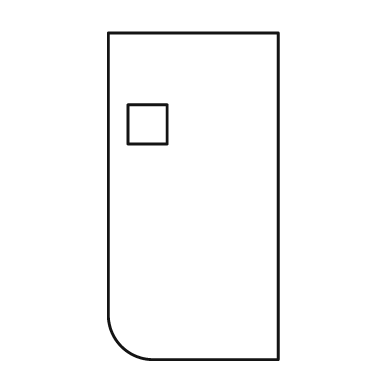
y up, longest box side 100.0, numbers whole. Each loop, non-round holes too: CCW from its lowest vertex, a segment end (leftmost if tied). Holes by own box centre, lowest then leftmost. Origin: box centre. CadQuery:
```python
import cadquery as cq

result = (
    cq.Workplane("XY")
    .moveTo(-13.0, -50.0)
    .lineTo(26.0, -50.0)
    .lineTo(26.0, 50.0)
    .lineTo(-26.0, 50.0)
    .lineTo(-26.0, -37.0)
    .threePointArc((-22.0, -46.0), (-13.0, -50.0))
    .close()
    .moveTo(-20.0, 16.0)
    .lineTo(-8.0, 16.0)
    .lineTo(-8.0, 28.0)
    .lineTo(-20.0, 28.0)
    .close()
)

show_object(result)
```